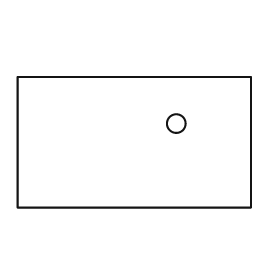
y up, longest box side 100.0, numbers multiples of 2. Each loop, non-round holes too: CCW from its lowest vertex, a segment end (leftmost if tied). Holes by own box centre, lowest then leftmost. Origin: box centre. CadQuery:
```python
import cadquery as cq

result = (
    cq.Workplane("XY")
    .moveTo(-50.0, -28.0)
    .lineTo(50.0, -28.0)
    .lineTo(50.0, 28.0)
    .lineTo(-50.0, 28.0)
    .close()
    .moveTo(18.0, 8.0)
    .circle(4.0)
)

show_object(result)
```